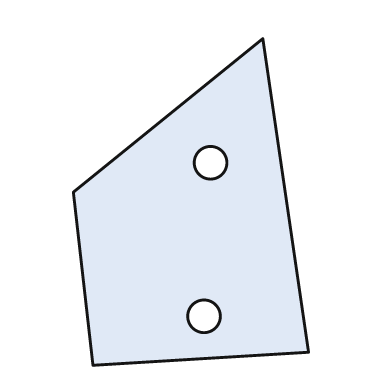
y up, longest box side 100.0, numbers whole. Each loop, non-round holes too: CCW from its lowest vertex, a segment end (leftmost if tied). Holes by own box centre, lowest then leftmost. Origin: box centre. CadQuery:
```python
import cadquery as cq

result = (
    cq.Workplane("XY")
    .moveTo(-30.0, -50.0)
    .lineTo(36.0, -46.0)
    .lineTo(22.0, 50.0)
    .lineTo(-36.0, 3.0)
    .close()
    .moveTo(4.0, -35.0)
    .circle(5.0)
    .moveTo(6.0, 12.0)
    .circle(5.0)
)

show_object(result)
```